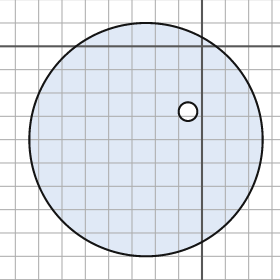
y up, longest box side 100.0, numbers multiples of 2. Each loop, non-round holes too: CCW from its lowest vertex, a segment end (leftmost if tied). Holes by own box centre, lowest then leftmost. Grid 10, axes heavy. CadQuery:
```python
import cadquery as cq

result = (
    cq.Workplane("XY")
    .moveTo(-24.0, -40.0)
    .circle(50.0)
    .moveTo(-6.0, -28.0)
    .circle(4.0)
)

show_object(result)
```